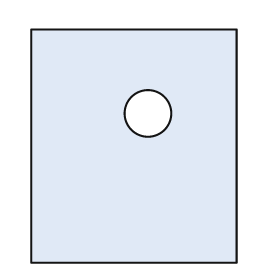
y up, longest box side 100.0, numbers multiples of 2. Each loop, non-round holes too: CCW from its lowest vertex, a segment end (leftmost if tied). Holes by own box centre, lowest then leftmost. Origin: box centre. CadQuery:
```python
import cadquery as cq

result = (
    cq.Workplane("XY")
    .moveTo(-44.0, -50.0)
    .lineTo(44.0, -50.0)
    .lineTo(44.0, 50.0)
    .lineTo(-44.0, 50.0)
    .close()
    .moveTo(6.0, 14.0)
    .circle(10.0)
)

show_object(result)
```